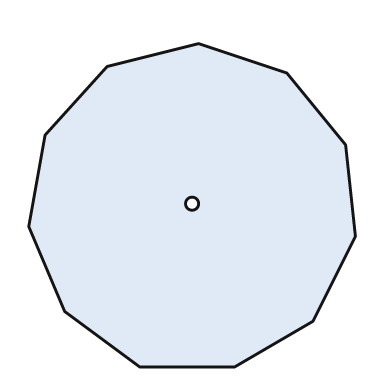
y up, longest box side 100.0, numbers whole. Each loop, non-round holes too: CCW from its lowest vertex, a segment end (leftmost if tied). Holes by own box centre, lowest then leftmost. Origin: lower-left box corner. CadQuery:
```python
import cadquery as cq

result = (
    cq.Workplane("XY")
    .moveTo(34.0, 0.0)
    .lineTo(63.0, 0.0)
    .lineTo(87.0, 14.0)
    .lineTo(100.0, 40.0)
    .lineTo(97.0, 68.0)
    .lineTo(79.0, 90.0)
    .lineTo(52.0, 99.0)
    .lineTo(24.0, 92.0)
    .lineTo(5.0, 71.0)
    .lineTo(0.0, 43.0)
    .lineTo(11.0, 17.0)
    .close()
    .moveTo(50.0, 50.0)
    .circle(2.0)
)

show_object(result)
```